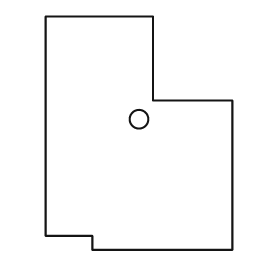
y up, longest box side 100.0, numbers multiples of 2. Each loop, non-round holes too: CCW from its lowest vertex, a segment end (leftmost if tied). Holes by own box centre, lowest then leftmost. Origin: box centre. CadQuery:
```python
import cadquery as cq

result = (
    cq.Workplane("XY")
    .moveTo(-20.0, -50.0)
    .lineTo(40.0, -50.0)
    .lineTo(40.0, 14.0)
    .lineTo(6.0, 14.0)
    .lineTo(6.0, 50.0)
    .lineTo(-40.0, 50.0)
    .lineTo(-40.0, -44.0)
    .lineTo(-20.0, -44.0)
    .close()
    .moveTo(0.0, 6.0)
    .circle(4.0)
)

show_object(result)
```